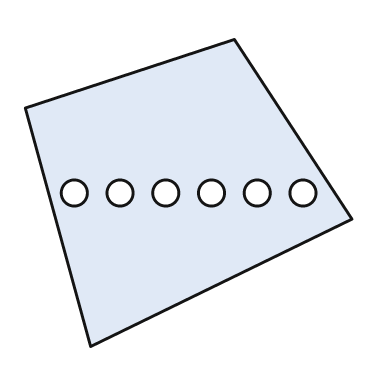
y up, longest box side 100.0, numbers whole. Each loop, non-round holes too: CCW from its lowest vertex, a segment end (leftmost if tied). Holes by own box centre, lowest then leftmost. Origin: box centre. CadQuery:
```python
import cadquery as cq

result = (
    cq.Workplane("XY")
    .moveTo(-30.0, -47.0)
    .lineTo(50.0, -8.0)
    .lineTo(14.0, 47.0)
    .lineTo(-50.0, 26.0)
    .close()
    .moveTo(-35.0, 0.0)
    .circle(4.0)
    .moveTo(-21.0, 0.0)
    .circle(4.0)
    .moveTo(-7.0, 0.0)
    .circle(4.0)
    .moveTo(7.0, 0.0)
    .circle(4.0)
    .moveTo(21.0, 0.0)
    .circle(4.0)
    .moveTo(35.0, 0.0)
    .circle(4.0)
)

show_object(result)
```